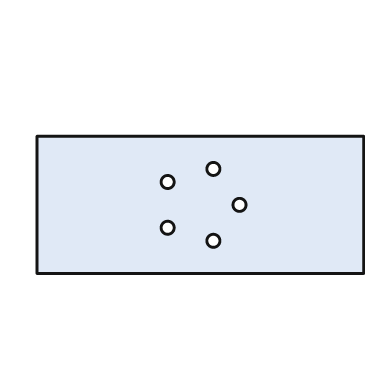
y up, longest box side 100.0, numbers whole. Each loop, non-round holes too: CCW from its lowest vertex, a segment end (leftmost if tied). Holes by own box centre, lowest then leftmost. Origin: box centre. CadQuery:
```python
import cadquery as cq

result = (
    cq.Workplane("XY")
    .moveTo(-50.0, -21.0)
    .lineTo(50.0, -21.0)
    .lineTo(50.0, 21.0)
    .lineTo(-50.0, 21.0)
    .close()
    .moveTo(4.0, -11.0)
    .circle(2.0)
    .moveTo(-10.0, -7.0)
    .circle(2.0)
    .moveTo(12.0, 0.0)
    .circle(2.0)
    .moveTo(-10.0, 7.0)
    .circle(2.0)
    .moveTo(4.0, 11.0)
    .circle(2.0)
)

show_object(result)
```